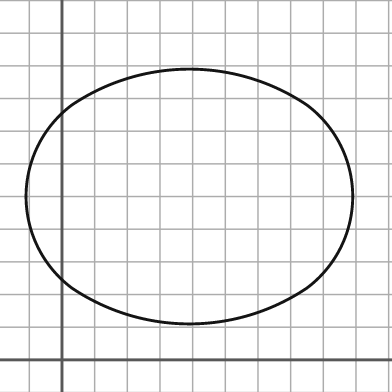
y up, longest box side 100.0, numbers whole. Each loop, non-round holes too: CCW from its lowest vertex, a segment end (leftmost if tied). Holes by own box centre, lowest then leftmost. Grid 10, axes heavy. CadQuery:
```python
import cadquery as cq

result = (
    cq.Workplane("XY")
    .moveTo(3.0, 22.0)
    .threePointArc((39.0, 11.0), (75.0, 22.0))
    .threePointArc((89.0, 50.0), (75.0, 78.0))
    .threePointArc((39.0, 89.0), (3.0, 78.0))
    .threePointArc((-11.0, 50.0), (3.0, 22.0))
    .close()
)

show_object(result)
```